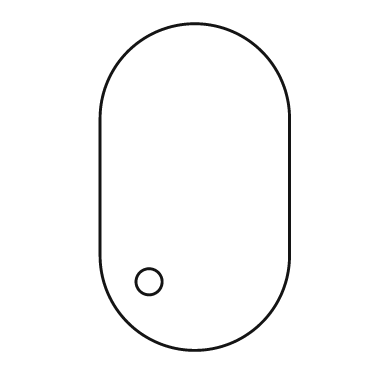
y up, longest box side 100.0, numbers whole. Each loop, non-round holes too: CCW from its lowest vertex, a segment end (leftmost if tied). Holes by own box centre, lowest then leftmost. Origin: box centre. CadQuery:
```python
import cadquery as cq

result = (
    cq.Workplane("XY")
    .moveTo(-29.0, -21.0)
    .threePointArc((0.0, -50.0), (29.0, -21.0))
    .lineTo(29.0, 21.0)
    .threePointArc((0.0, 50.0), (-29.0, 21.0))
    .close()
    .moveTo(-14.0, -29.0)
    .circle(4.0)
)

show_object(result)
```